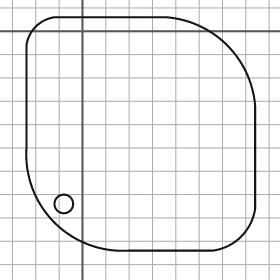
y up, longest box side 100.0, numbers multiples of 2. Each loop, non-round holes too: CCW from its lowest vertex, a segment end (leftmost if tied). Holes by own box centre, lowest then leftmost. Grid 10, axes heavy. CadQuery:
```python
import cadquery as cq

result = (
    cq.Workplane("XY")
    .moveTo(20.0, -94.0)
    .lineTo(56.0, -94.0)
    .threePointArc((68.0, -88.0), (74.0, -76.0))
    .lineTo(74.0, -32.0)
    .threePointArc((62.0, -6.0), (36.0, 6.0))
    .lineTo(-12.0, 6.0)
    .threePointArc((-20.0, 2.0), (-24.0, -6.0))
    .lineTo(-24.0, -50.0)
    .threePointArc((-12.0, -82.0), (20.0, -94.0))
    .close()
    .moveTo(-8.0, -74.0)
    .circle(4.0)
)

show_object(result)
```